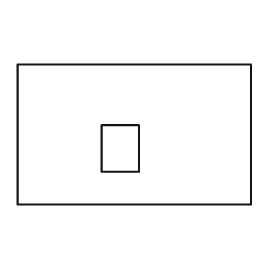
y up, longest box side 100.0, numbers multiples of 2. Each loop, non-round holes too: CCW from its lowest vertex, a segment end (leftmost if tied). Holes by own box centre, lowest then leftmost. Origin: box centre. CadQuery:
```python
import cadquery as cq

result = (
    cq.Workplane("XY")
    .moveTo(-50.0, -30.0)
    .lineTo(50.0, -30.0)
    .lineTo(50.0, 30.0)
    .lineTo(-50.0, 30.0)
    .close()
    .moveTo(-14.0, -16.0)
    .lineTo(2.0, -16.0)
    .lineTo(2.0, 4.0)
    .lineTo(-14.0, 4.0)
    .close()
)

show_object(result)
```